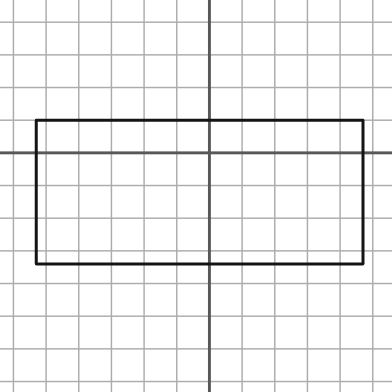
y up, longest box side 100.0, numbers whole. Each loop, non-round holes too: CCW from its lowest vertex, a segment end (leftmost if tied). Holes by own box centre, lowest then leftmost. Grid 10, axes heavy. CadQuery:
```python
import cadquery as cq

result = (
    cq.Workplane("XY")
    .moveTo(-53.0, -34.0)
    .lineTo(47.0, -34.0)
    .lineTo(47.0, 10.0)
    .lineTo(-53.0, 10.0)
    .close()
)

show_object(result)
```